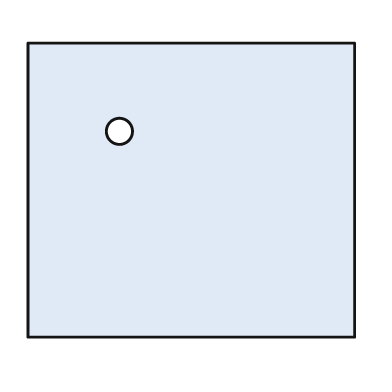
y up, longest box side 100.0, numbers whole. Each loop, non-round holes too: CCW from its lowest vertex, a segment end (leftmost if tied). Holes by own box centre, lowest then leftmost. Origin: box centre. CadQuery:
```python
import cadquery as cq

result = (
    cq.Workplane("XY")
    .moveTo(-50.0, -45.0)
    .lineTo(50.0, -45.0)
    .lineTo(50.0, 45.0)
    .lineTo(-50.0, 45.0)
    .close()
    .moveTo(-22.0, 18.0)
    .circle(4.0)
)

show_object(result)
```